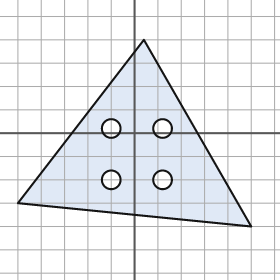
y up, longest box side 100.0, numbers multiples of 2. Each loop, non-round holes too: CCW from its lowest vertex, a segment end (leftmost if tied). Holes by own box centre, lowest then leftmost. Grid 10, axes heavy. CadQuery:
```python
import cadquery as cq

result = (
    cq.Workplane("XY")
    .moveTo(50.0, -40.0)
    .lineTo(4.0, 40.0)
    .lineTo(-50.0, -30.0)
    .close()
    .moveTo(-10.0, -20.0)
    .circle(4.0)
    .moveTo(12.0, -20.0)
    .circle(4.0)
    .moveTo(-10.0, 2.0)
    .circle(4.0)
    .moveTo(12.0, 2.0)
    .circle(4.0)
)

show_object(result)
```